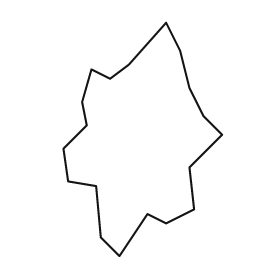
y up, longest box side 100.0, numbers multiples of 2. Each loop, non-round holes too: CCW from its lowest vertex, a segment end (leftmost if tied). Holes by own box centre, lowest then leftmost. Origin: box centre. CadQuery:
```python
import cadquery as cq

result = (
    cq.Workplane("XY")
    .moveTo(-10.0, -50.0)
    .lineTo(2.0, -32.0)
    .lineTo(10.0, -36.0)
    .lineTo(22.0, -30.0)
    .lineTo(20.0, -12.0)
    .lineTo(34.0, 2.0)
    .lineTo(26.0, 10.0)
    .lineTo(20.0, 22.0)
    .lineTo(16.0, 38.0)
    .lineTo(10.0, 50.0)
    .lineTo(-6.0, 32.0)
    .lineTo(-14.0, 26.0)
    .lineTo(-22.0, 30.0)
    .lineTo(-26.0, 16.0)
    .lineTo(-24.0, 6.0)
    .lineTo(-34.0, -4.0)
    .lineTo(-32.0, -18.0)
    .lineTo(-20.0, -20.0)
    .lineTo(-18.0, -42.0)
    .close()
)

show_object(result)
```